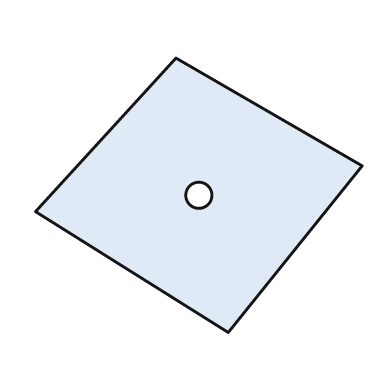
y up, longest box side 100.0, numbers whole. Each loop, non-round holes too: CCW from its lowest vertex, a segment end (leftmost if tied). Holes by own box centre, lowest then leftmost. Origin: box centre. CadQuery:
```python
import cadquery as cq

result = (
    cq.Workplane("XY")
    .moveTo(9.0, -42.0)
    .lineTo(50.0, 9.0)
    .lineTo(-7.0, 42.0)
    .lineTo(-50.0, -5.0)
    .close()
    .moveTo(0.0, 0.0)
    .circle(4.0)
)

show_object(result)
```